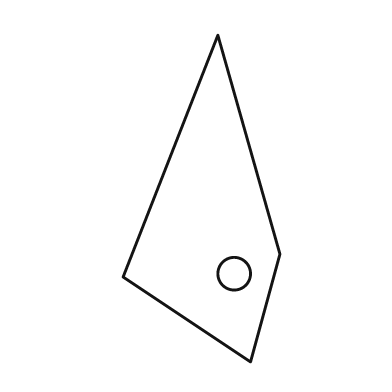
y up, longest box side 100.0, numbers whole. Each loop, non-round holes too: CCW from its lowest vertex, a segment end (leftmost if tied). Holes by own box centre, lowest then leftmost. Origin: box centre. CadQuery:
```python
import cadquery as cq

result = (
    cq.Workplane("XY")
    .moveTo(15.0, -50.0)
    .lineTo(24.0, -17.0)
    .lineTo(5.0, 50.0)
    .lineTo(-24.0, -24.0)
    .close()
    .moveTo(10.0, -23.0)
    .circle(5.0)
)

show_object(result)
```